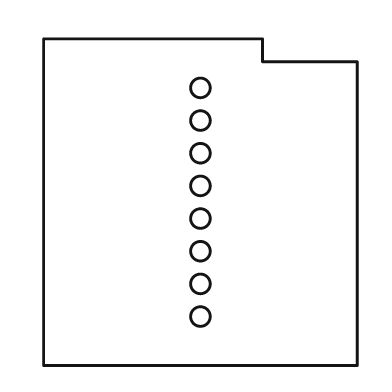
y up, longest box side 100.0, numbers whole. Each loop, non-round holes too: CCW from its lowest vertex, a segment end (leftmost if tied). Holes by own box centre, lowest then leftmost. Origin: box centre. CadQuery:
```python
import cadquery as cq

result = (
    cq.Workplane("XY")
    .moveTo(-48.0, -50.0)
    .lineTo(48.0, -50.0)
    .lineTo(48.0, 43.0)
    .lineTo(19.0, 43.0)
    .lineTo(19.0, 50.0)
    .lineTo(-48.0, 50.0)
    .close()
    .moveTo(0.0, -35.0)
    .circle(3.0)
    .moveTo(0.0, -25.0)
    .circle(3.0)
    .moveTo(0.0, -15.0)
    .circle(3.0)
    .moveTo(0.0, -5.0)
    .circle(3.0)
    .moveTo(0.0, 5.0)
    .circle(3.0)
    .moveTo(0.0, 15.0)
    .circle(3.0)
    .moveTo(0.0, 25.0)
    .circle(3.0)
    .moveTo(0.0, 35.0)
    .circle(3.0)
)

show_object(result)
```